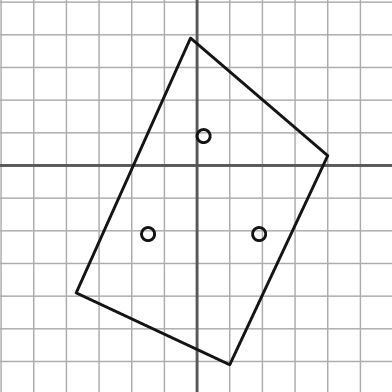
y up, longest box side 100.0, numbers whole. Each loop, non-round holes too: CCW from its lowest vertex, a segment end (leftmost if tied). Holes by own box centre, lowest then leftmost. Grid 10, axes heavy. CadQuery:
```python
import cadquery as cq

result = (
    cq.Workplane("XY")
    .moveTo(10.0, -61.0)
    .lineTo(40.0, 3.0)
    .lineTo(-2.0, 39.0)
    .lineTo(-37.0, -39.0)
    .close()
    .moveTo(-15.0, -21.0)
    .circle(2.0)
    .moveTo(19.0, -21.0)
    .circle(2.0)
    .moveTo(2.0, 9.0)
    .circle(2.0)
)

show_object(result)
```